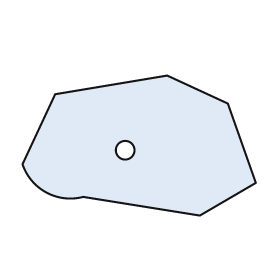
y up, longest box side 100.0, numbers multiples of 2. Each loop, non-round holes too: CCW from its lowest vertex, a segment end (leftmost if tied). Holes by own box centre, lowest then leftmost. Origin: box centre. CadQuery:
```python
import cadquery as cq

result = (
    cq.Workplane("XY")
    .moveTo(26.0, -30.0)
    .lineTo(50.0, -16.0)
    .lineTo(38.0, 18.0)
    .lineTo(12.0, 30.0)
    .lineTo(-36.0, 22.0)
    .lineTo(-50.0, -8.0)
    .threePointArc((-40.0, -20.0), (-24.0, -22.0))
    .close()
    .moveTo(-6.0, -2.0)
    .circle(4.0)
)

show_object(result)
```